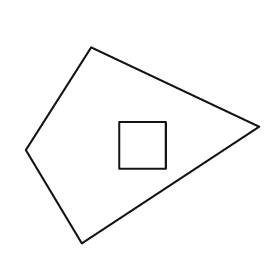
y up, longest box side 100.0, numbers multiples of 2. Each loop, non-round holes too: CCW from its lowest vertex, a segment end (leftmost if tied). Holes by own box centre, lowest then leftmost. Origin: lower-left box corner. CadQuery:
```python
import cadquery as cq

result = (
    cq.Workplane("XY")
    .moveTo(24.0, 0.0)
    .lineTo(100.0, 50.0)
    .lineTo(28.0, 84.0)
    .lineTo(0.0, 40.0)
    .close()
    .moveTo(40.0, 32.0)
    .lineTo(60.0, 32.0)
    .lineTo(60.0, 52.0)
    .lineTo(40.0, 52.0)
    .close()
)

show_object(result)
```